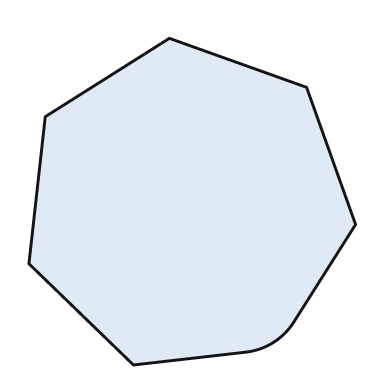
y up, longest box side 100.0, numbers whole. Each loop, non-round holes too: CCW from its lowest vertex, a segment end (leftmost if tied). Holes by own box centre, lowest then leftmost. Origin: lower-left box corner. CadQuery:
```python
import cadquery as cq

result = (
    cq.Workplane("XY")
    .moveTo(32.0, 0.0)
    .lineTo(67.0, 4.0)
    .threePointArc((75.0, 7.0), (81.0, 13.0))
    .lineTo(100.0, 43.0)
    .lineTo(85.0, 85.0)
    .lineTo(43.0, 100.0)
    .lineTo(5.0, 76.0)
    .lineTo(0.0, 31.0)
    .close()
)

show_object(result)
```